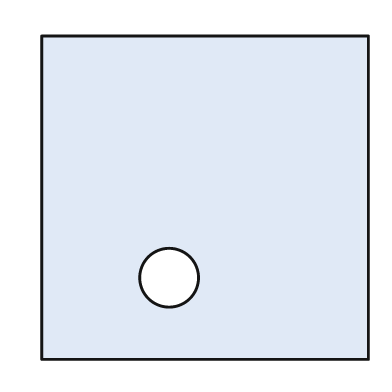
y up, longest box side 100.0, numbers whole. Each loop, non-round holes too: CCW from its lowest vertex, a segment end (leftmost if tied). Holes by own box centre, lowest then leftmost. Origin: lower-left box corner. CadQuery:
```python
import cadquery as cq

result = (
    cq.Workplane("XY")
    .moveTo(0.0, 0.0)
    .lineTo(100.0, 0.0)
    .lineTo(100.0, 99.0)
    .lineTo(0.0, 99.0)
    .close()
    .moveTo(39.0, 25.0)
    .circle(9.0)
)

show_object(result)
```